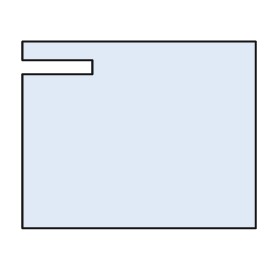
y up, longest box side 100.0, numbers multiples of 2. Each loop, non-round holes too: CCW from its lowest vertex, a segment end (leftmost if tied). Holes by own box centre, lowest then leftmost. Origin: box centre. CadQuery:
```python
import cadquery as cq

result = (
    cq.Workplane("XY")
    .moveTo(-50.0, -40.0)
    .lineTo(50.0, -40.0)
    .lineTo(50.0, 40.0)
    .lineTo(-50.0, 40.0)
    .lineTo(-50.0, 32.0)
    .lineTo(-20.0, 32.0)
    .lineTo(-20.0, 26.0)
    .lineTo(-50.0, 26.0)
    .close()
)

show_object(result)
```